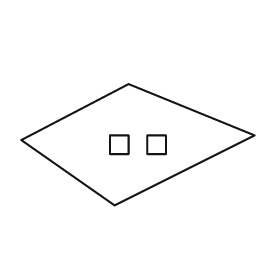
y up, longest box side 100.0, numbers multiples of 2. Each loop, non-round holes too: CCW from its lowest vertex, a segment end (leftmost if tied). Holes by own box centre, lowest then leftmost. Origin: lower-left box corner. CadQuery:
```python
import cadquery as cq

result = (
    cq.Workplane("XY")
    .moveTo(40.0, 0.0)
    .lineTo(100.0, 30.0)
    .lineTo(46.0, 52.0)
    .lineTo(0.0, 28.0)
    .close()
    .moveTo(38.0, 22.0)
    .lineTo(46.0, 22.0)
    .lineTo(46.0, 30.0)
    .lineTo(38.0, 30.0)
    .close()
    .moveTo(54.0, 22.0)
    .lineTo(62.0, 22.0)
    .lineTo(62.0, 30.0)
    .lineTo(54.0, 30.0)
    .close()
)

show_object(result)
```